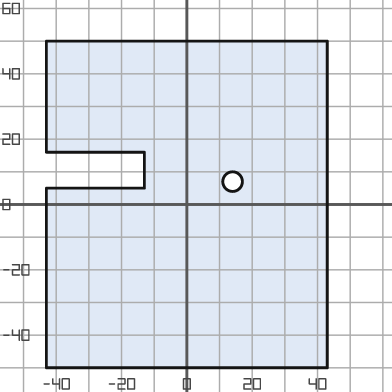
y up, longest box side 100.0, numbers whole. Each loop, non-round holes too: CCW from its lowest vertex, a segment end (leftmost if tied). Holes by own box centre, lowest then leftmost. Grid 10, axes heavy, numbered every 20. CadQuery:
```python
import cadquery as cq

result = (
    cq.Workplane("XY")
    .moveTo(-43.0, -50.0)
    .lineTo(43.0, -50.0)
    .lineTo(43.0, 50.0)
    .lineTo(-43.0, 50.0)
    .lineTo(-43.0, 16.0)
    .lineTo(-13.0, 16.0)
    .lineTo(-13.0, 5.0)
    .lineTo(-43.0, 5.0)
    .close()
    .moveTo(14.0, 7.0)
    .circle(3.0)
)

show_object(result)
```